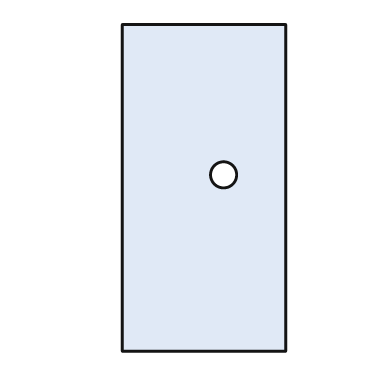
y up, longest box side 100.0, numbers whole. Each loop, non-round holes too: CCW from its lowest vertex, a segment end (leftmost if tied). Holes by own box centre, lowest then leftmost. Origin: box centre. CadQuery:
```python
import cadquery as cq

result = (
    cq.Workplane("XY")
    .moveTo(-25.0, -50.0)
    .lineTo(25.0, -50.0)
    .lineTo(25.0, 50.0)
    .lineTo(-25.0, 50.0)
    .close()
    .moveTo(6.0, 4.0)
    .circle(4.0)
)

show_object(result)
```